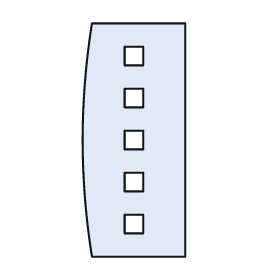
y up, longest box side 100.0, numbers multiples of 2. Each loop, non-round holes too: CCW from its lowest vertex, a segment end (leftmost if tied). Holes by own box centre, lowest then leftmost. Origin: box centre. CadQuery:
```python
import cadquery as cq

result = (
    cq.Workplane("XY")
    .moveTo(-18.0, -50.0)
    .lineTo(22.0, -50.0)
    .lineTo(22.0, 50.0)
    .lineTo(-18.0, 50.0)
    .threePointArc((-22.0, 0.0), (-18.0, -50.0))
    .close()
    .moveTo(-4.0, -40.0)
    .lineTo(4.0, -40.0)
    .lineTo(4.0, -32.0)
    .lineTo(-4.0, -32.0)
    .close()
    .moveTo(-4.0, -22.0)
    .lineTo(4.0, -22.0)
    .lineTo(4.0, -14.0)
    .lineTo(-4.0, -14.0)
    .close()
    .moveTo(-4.0, -4.0)
    .lineTo(4.0, -4.0)
    .lineTo(4.0, 4.0)
    .lineTo(-4.0, 4.0)
    .close()
    .moveTo(-4.0, 14.0)
    .lineTo(4.0, 14.0)
    .lineTo(4.0, 22.0)
    .lineTo(-4.0, 22.0)
    .close()
    .moveTo(-4.0, 32.0)
    .lineTo(4.0, 32.0)
    .lineTo(4.0, 40.0)
    .lineTo(-4.0, 40.0)
    .close()
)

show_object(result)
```